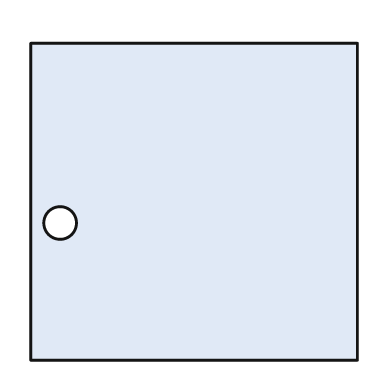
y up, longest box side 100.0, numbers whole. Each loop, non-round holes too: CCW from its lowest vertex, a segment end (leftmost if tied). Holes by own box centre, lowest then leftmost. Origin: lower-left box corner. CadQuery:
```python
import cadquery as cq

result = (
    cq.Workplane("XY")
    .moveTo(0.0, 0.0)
    .lineTo(100.0, 0.0)
    .lineTo(100.0, 97.0)
    .lineTo(0.0, 97.0)
    .close()
    .moveTo(9.0, 42.0)
    .circle(5.0)
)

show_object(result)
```